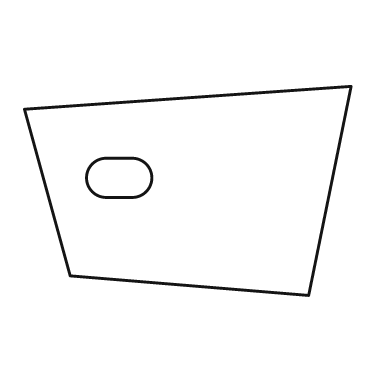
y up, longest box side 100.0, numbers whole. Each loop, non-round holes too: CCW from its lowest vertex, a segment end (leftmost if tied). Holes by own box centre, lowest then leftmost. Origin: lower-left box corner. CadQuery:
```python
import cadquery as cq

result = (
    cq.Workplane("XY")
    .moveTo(87.0, 0.0)
    .lineTo(100.0, 64.0)
    .lineTo(0.0, 57.0)
    .lineTo(14.0, 6.0)
    .close()
    .moveTo(25.0, 30.0)
    .lineTo(33.0, 30.0)
    .threePointArc((39.0, 36.0), (33.0, 42.0))
    .lineTo(25.0, 42.0)
    .threePointArc((19.0, 36.0), (25.0, 30.0))
    .close()
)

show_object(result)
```